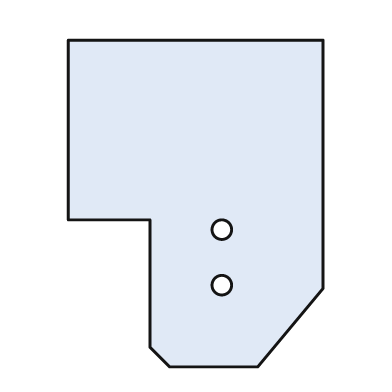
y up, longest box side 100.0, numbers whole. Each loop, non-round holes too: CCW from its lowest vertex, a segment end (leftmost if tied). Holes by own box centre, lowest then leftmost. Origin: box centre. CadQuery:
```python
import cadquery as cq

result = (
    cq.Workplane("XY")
    .moveTo(-8.0, -50.0)
    .lineTo(19.0, -50.0)
    .lineTo(39.0, -26.0)
    .lineTo(39.0, 50.0)
    .lineTo(-39.0, 50.0)
    .lineTo(-39.0, -5.0)
    .lineTo(-14.0, -5.0)
    .lineTo(-14.0, -44.0)
    .close()
    .moveTo(8.0, -25.0)
    .circle(3.0)
    .moveTo(8.0, -8.0)
    .circle(3.0)
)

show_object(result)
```